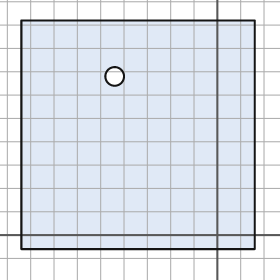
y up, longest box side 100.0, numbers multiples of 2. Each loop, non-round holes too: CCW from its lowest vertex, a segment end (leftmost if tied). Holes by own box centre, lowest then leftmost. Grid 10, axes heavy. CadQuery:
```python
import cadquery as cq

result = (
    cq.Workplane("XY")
    .moveTo(-84.0, -6.0)
    .lineTo(16.0, -6.0)
    .lineTo(16.0, 92.0)
    .lineTo(-84.0, 92.0)
    .close()
    .moveTo(-44.0, 68.0)
    .circle(4.0)
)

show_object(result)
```